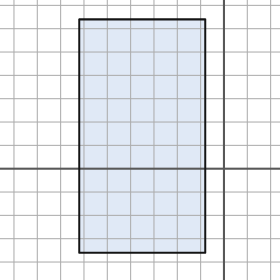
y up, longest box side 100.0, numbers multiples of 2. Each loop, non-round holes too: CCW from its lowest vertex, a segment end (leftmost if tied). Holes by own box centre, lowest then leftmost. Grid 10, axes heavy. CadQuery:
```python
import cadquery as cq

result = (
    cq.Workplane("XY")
    .moveTo(-62.0, -36.0)
    .lineTo(-8.0, -36.0)
    .lineTo(-8.0, 64.0)
    .lineTo(-62.0, 64.0)
    .close()
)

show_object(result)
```